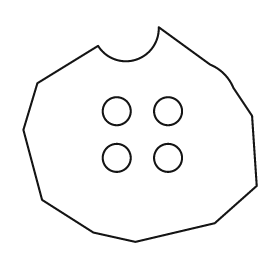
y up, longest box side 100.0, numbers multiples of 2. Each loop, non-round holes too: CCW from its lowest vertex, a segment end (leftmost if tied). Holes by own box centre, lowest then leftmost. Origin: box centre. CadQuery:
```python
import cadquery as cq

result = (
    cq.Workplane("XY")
    .moveTo(-2.0, -46.0)
    .lineTo(32.0, -38.0)
    .lineTo(50.0, -22.0)
    .lineTo(48.0, 8.0)
    .lineTo(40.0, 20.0)
    .threePointArc((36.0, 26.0), (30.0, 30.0))
    .lineTo(8.0, 46.0)
    .threePointArc((-2.0, 32.0), (-18.0, 38.0))
    .lineTo(-44.0, 22.0)
    .lineTo(-50.0, 2.0)
    .lineTo(-42.0, -28.0)
    .lineTo(-20.0, -42.0)
    .close()
    .moveTo(-10.0, -10.0)
    .circle(6.0)
    .moveTo(12.0, -10.0)
    .circle(6.0)
    .moveTo(-10.0, 10.0)
    .circle(6.0)
    .moveTo(12.0, 10.0)
    .circle(6.0)
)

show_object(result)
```